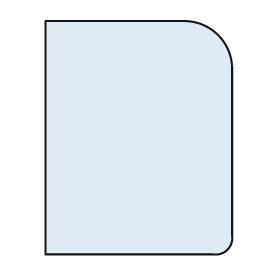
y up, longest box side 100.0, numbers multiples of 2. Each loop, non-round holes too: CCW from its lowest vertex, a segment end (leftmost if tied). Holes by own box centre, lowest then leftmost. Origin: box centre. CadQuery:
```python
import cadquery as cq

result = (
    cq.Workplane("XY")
    .moveTo(-40.0, -50.0)
    .lineTo(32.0, -50.0)
    .threePointArc((38.0, -48.0), (40.0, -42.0))
    .lineTo(40.0, 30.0)
    .threePointArc((34.0, 44.0), (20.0, 50.0))
    .lineTo(-40.0, 50.0)
    .close()
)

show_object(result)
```